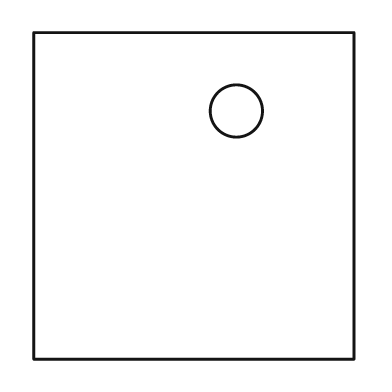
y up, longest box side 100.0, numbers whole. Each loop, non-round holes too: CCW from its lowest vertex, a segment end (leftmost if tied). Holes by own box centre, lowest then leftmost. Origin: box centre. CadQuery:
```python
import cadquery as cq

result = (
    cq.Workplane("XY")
    .moveTo(-49.0, -50.0)
    .lineTo(49.0, -50.0)
    .lineTo(49.0, 50.0)
    .lineTo(-49.0, 50.0)
    .close()
    .moveTo(13.0, 26.0)
    .circle(8.0)
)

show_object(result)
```